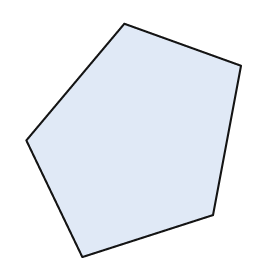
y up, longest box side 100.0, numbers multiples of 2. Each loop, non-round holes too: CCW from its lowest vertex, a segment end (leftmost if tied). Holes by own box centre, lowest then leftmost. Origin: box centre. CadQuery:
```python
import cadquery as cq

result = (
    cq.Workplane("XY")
    .moveTo(-22.0, -50.0)
    .lineTo(34.0, -32.0)
    .lineTo(46.0, 32.0)
    .lineTo(-4.0, 50.0)
    .lineTo(-46.0, 0.0)
    .close()
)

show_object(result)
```